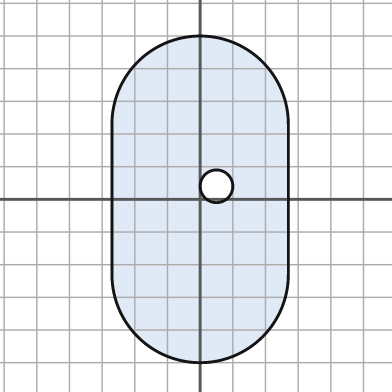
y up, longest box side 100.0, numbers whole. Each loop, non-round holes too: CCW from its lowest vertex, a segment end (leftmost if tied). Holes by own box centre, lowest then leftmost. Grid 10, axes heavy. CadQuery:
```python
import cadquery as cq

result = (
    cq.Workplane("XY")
    .moveTo(-27.0, -23.0)
    .threePointArc((0.0, -50.0), (27.0, -23.0))
    .lineTo(27.0, 23.0)
    .threePointArc((0.0, 50.0), (-27.0, 23.0))
    .close()
    .moveTo(5.0, 4.0)
    .circle(5.0)
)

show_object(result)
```